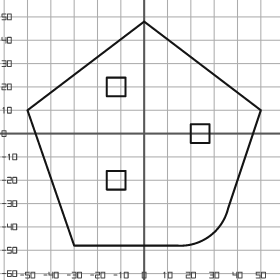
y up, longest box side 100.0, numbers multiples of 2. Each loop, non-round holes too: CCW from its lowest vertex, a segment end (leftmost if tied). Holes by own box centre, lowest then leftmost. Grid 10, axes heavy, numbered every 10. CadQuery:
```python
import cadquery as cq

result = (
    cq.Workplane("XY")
    .moveTo(-30.0, -48.0)
    .lineTo(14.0, -48.0)
    .threePointArc((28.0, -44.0), (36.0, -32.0))
    .lineTo(50.0, 10.0)
    .lineTo(0.0, 48.0)
    .lineTo(-50.0, 10.0)
    .close()
    .moveTo(-16.0, -24.0)
    .lineTo(-8.0, -24.0)
    .lineTo(-8.0, -16.0)
    .lineTo(-16.0, -16.0)
    .close()
    .moveTo(20.0, -4.0)
    .lineTo(28.0, -4.0)
    .lineTo(28.0, 4.0)
    .lineTo(20.0, 4.0)
    .close()
    .moveTo(-16.0, 16.0)
    .lineTo(-8.0, 16.0)
    .lineTo(-8.0, 24.0)
    .lineTo(-16.0, 24.0)
    .close()
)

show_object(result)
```